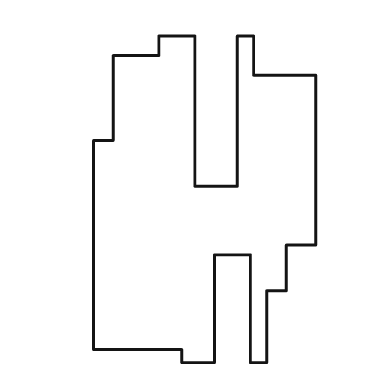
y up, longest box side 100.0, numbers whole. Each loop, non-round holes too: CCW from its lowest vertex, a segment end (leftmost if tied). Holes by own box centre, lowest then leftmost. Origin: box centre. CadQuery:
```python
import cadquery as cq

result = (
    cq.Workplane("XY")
    .moveTo(-7.0, -50.0)
    .lineTo(3.0, -50.0)
    .lineTo(3.0, -17.0)
    .lineTo(14.0, -17.0)
    .lineTo(14.0, -50.0)
    .lineTo(19.0, -50.0)
    .lineTo(19.0, -28.0)
    .lineTo(25.0, -28.0)
    .lineTo(25.0, -14.0)
    .lineTo(34.0, -14.0)
    .lineTo(34.0, 38.0)
    .lineTo(15.0, 38.0)
    .lineTo(15.0, 50.0)
    .lineTo(10.0, 50.0)
    .lineTo(10.0, 4.0)
    .lineTo(-3.0, 4.0)
    .lineTo(-3.0, 50.0)
    .lineTo(-14.0, 50.0)
    .lineTo(-14.0, 44.0)
    .lineTo(-28.0, 44.0)
    .lineTo(-28.0, 18.0)
    .lineTo(-34.0, 18.0)
    .lineTo(-34.0, -46.0)
    .lineTo(-7.0, -46.0)
    .close()
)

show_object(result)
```